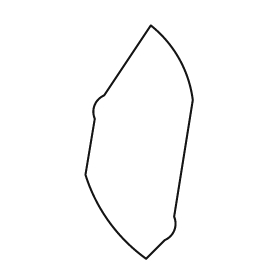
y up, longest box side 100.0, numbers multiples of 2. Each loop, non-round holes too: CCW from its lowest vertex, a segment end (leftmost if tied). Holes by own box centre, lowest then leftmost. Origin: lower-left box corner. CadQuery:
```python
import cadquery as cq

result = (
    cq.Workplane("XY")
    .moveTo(26.0, 0.0)
    .lineTo(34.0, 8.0)
    .threePointArc((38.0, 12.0), (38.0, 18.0))
    .lineTo(46.0, 68.0)
    .threePointArc((40.0, 86.0), (28.0, 100.0))
    .lineTo(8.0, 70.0)
    .threePointArc((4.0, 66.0), (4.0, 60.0))
    .lineTo(0.0, 36.0)
    .threePointArc((10.0, 16.0), (26.0, 0.0))
    .close()
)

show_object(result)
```